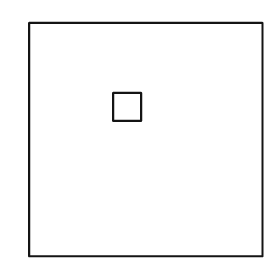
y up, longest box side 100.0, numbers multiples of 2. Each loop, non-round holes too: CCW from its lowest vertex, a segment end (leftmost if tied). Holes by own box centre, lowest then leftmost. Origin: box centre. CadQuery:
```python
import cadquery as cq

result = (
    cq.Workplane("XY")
    .moveTo(-50.0, -50.0)
    .lineTo(50.0, -50.0)
    .lineTo(50.0, 50.0)
    .lineTo(-50.0, 50.0)
    .close()
    .moveTo(-14.0, 8.0)
    .lineTo(-2.0, 8.0)
    .lineTo(-2.0, 20.0)
    .lineTo(-14.0, 20.0)
    .close()
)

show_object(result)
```